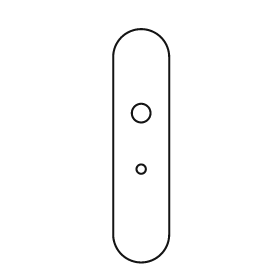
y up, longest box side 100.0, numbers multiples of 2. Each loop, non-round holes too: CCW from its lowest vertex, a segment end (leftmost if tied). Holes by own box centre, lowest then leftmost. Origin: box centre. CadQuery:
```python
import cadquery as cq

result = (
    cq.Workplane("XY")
    .moveTo(-12.0, -38.0)
    .threePointArc((0.0, -50.0), (12.0, -38.0))
    .lineTo(12.0, 38.0)
    .threePointArc((0.0, 50.0), (-12.0, 38.0))
    .close()
    .moveTo(0.0, -10.0)
    .circle(2.0)
    .moveTo(0.0, 14.0)
    .circle(4.0)
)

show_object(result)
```